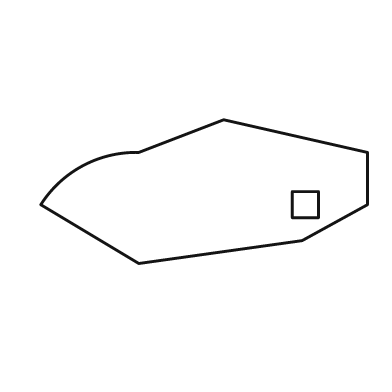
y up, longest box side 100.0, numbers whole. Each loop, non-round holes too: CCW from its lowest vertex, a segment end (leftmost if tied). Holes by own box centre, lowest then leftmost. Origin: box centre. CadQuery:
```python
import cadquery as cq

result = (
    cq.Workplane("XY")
    .moveTo(-20.0, -22.0)
    .lineTo(30.0, -15.0)
    .lineTo(50.0, -4.0)
    .lineTo(50.0, 12.0)
    .lineTo(6.0, 22.0)
    .lineTo(-20.0, 12.0)
    .threePointArc((-37.0, 8.0), (-50.0, -4.0))
    .close()
    .moveTo(27.0, -8.0)
    .lineTo(35.0, -8.0)
    .lineTo(35.0, 0.0)
    .lineTo(27.0, 0.0)
    .close()
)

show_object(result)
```